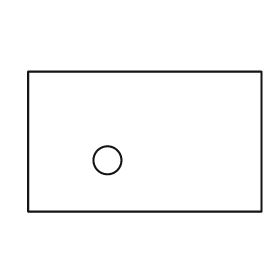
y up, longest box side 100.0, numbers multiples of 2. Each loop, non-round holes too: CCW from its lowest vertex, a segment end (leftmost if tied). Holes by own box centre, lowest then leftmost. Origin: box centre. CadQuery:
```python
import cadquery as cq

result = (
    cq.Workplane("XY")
    .moveTo(-50.0, -30.0)
    .lineTo(50.0, -30.0)
    .lineTo(50.0, 30.0)
    .lineTo(-50.0, 30.0)
    .close()
    .moveTo(-16.0, -8.0)
    .circle(6.0)
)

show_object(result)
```